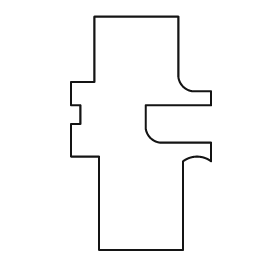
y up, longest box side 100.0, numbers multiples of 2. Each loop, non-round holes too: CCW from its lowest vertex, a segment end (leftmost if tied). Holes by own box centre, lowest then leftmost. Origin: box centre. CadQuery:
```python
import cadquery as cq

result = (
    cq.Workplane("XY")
    .moveTo(-18.0, -50.0)
    .lineTo(18.0, -50.0)
    .lineTo(18.0, -12.0)
    .threePointArc((24.0, -10.0), (30.0, -12.0))
    .lineTo(30.0, -4.0)
    .lineTo(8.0, -4.0)
    .threePointArc((4.0, -2.0), (2.0, 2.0))
    .lineTo(2.0, 12.0)
    .lineTo(30.0, 12.0)
    .lineTo(30.0, 18.0)
    .lineTo(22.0, 18.0)
    .threePointArc((18.0, 20.0), (16.0, 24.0))
    .lineTo(16.0, 50.0)
    .lineTo(-20.0, 50.0)
    .lineTo(-20.0, 22.0)
    .lineTo(-30.0, 22.0)
    .lineTo(-30.0, 12.0)
    .lineTo(-26.0, 12.0)
    .lineTo(-26.0, 4.0)
    .lineTo(-30.0, 4.0)
    .lineTo(-30.0, -10.0)
    .lineTo(-18.0, -10.0)
    .close()
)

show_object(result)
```